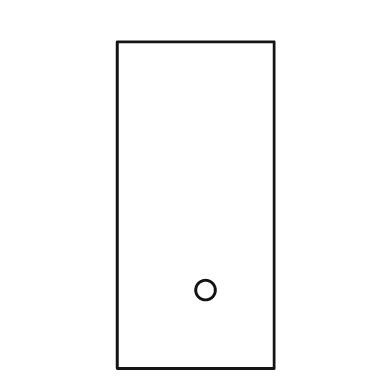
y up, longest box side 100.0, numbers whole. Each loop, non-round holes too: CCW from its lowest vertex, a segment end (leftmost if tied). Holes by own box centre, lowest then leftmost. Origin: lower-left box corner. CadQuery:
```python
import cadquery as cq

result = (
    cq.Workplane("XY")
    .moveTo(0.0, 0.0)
    .lineTo(48.0, 0.0)
    .lineTo(48.0, 100.0)
    .lineTo(0.0, 100.0)
    .close()
    .moveTo(27.0, 24.0)
    .circle(3.0)
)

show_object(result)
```